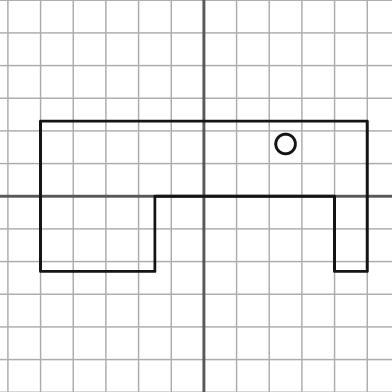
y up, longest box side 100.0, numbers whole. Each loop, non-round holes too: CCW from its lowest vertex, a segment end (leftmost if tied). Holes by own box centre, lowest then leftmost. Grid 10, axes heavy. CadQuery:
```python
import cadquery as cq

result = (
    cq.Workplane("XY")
    .moveTo(-50.0, -23.0)
    .lineTo(-15.0, -23.0)
    .lineTo(-15.0, 0.0)
    .lineTo(40.0, 0.0)
    .lineTo(40.0, -23.0)
    .lineTo(50.0, -23.0)
    .lineTo(50.0, 23.0)
    .lineTo(-50.0, 23.0)
    .close()
    .moveTo(25.0, 16.0)
    .circle(3.0)
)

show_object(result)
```